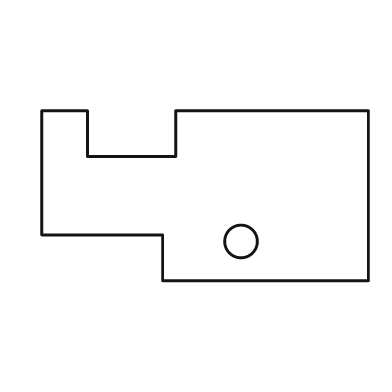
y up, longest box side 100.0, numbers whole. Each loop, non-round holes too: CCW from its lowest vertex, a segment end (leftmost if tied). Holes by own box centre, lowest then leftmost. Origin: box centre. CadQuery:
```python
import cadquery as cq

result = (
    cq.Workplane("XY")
    .moveTo(-13.0, -26.0)
    .lineTo(50.0, -26.0)
    .lineTo(50.0, 26.0)
    .lineTo(-9.0, 26.0)
    .lineTo(-9.0, 12.0)
    .lineTo(-36.0, 12.0)
    .lineTo(-36.0, 26.0)
    .lineTo(-50.0, 26.0)
    .lineTo(-50.0, -12.0)
    .lineTo(-13.0, -12.0)
    .close()
    .moveTo(11.0, -14.0)
    .circle(5.0)
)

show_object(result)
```